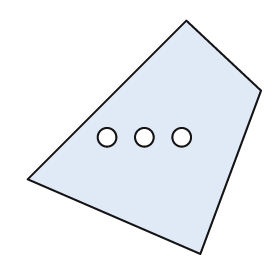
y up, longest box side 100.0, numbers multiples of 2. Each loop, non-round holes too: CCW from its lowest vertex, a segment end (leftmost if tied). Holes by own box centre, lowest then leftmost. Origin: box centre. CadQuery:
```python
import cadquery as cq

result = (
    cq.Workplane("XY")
    .moveTo(24.0, -50.0)
    .lineTo(50.0, 20.0)
    .lineTo(18.0, 50.0)
    .lineTo(-50.0, -18.0)
    .close()
    .moveTo(-16.0, 0.0)
    .circle(4.0)
    .moveTo(0.0, 0.0)
    .circle(4.0)
    .moveTo(16.0, 0.0)
    .circle(4.0)
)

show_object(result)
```